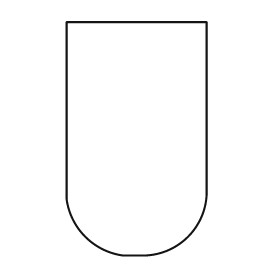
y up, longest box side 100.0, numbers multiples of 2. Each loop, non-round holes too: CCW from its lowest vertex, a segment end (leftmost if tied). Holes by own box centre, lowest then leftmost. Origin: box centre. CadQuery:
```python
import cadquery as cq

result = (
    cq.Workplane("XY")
    .moveTo(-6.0, -50.0)
    .lineTo(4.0, -50.0)
    .threePointArc((22.0, -42.0), (30.0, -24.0))
    .lineTo(30.0, 50.0)
    .lineTo(-30.0, 50.0)
    .lineTo(-30.0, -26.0)
    .threePointArc((-22.0, -42.0), (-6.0, -50.0))
    .close()
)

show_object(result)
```